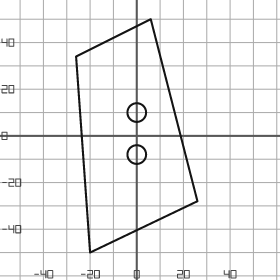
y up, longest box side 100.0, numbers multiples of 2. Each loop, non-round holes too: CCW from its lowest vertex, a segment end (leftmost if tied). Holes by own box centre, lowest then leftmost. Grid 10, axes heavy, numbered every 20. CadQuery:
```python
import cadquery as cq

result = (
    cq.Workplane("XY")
    .moveTo(-20.0, -50.0)
    .lineTo(26.0, -28.0)
    .lineTo(6.0, 50.0)
    .lineTo(-26.0, 34.0)
    .close()
    .moveTo(0.0, -8.0)
    .circle(4.0)
    .moveTo(0.0, 10.0)
    .circle(4.0)
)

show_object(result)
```